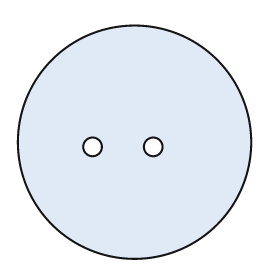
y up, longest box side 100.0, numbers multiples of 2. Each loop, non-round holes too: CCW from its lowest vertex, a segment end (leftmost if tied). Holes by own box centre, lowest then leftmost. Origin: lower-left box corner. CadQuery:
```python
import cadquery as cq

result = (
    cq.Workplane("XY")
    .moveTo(50.0, 50.0)
    .circle(50.0)
    .moveTo(32.0, 48.0)
    .circle(4.0)
    .moveTo(58.0, 48.0)
    .circle(4.0)
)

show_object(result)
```